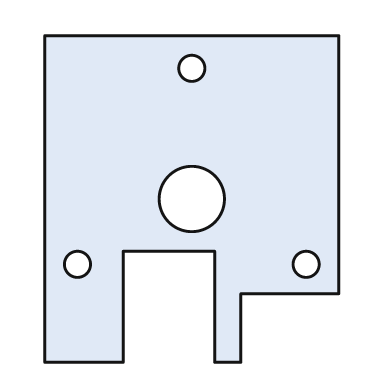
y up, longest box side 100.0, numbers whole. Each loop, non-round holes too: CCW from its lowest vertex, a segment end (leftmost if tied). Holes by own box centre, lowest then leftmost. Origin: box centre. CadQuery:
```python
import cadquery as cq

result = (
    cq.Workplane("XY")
    .moveTo(-45.0, -50.0)
    .lineTo(-21.0, -50.0)
    .lineTo(-21.0, -16.0)
    .lineTo(7.0, -16.0)
    .lineTo(7.0, -50.0)
    .lineTo(15.0, -50.0)
    .lineTo(15.0, -29.0)
    .lineTo(45.0, -29.0)
    .lineTo(45.0, 50.0)
    .lineTo(-45.0, 50.0)
    .close()
    .moveTo(-35.0, -20.0)
    .circle(4.0)
    .moveTo(35.0, -20.0)
    .circle(4.0)
    .moveTo(0.0, 0.0)
    .circle(10.0)
    .moveTo(0.0, 40.0)
    .circle(4.0)
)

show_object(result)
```